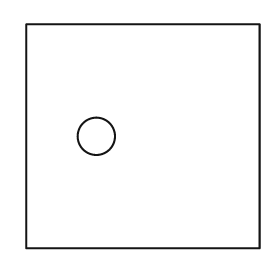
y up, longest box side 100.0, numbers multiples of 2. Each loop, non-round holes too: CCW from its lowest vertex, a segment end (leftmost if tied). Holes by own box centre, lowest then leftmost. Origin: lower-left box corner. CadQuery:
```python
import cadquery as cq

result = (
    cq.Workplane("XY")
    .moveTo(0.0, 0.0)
    .lineTo(100.0, 0.0)
    .lineTo(100.0, 96.0)
    .lineTo(0.0, 96.0)
    .close()
    .moveTo(30.0, 48.0)
    .circle(8.0)
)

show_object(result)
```